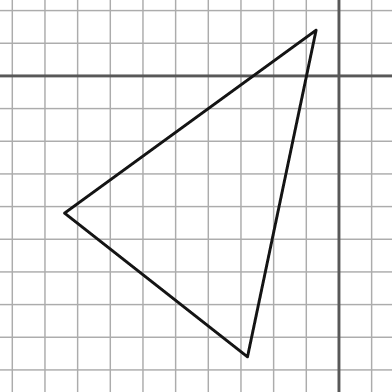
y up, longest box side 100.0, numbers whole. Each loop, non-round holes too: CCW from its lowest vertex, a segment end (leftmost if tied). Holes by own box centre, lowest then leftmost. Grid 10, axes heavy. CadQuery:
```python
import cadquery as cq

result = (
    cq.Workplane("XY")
    .moveTo(-28.0, -86.0)
    .lineTo(-7.0, 14.0)
    .lineTo(-84.0, -42.0)
    .close()
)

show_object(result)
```